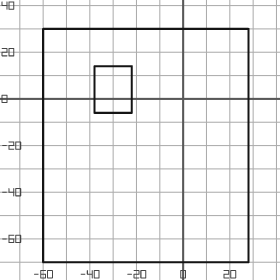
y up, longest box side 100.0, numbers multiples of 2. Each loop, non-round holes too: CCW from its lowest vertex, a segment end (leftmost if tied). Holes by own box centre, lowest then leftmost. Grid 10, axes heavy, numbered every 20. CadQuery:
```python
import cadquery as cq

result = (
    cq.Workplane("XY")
    .moveTo(-60.0, -70.0)
    .lineTo(28.0, -70.0)
    .lineTo(28.0, 30.0)
    .lineTo(-60.0, 30.0)
    .close()
    .moveTo(-38.0, -6.0)
    .lineTo(-22.0, -6.0)
    .lineTo(-22.0, 14.0)
    .lineTo(-38.0, 14.0)
    .close()
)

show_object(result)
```